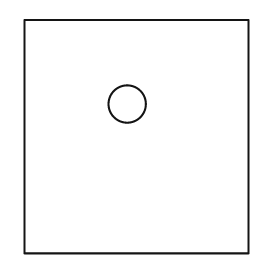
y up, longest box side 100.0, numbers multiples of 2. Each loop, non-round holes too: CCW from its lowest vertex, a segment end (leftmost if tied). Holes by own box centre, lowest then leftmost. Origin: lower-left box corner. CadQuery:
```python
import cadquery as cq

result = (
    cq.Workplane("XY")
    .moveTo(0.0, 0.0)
    .lineTo(96.0, 0.0)
    .lineTo(96.0, 100.0)
    .lineTo(0.0, 100.0)
    .close()
    .moveTo(44.0, 64.0)
    .circle(8.0)
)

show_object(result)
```